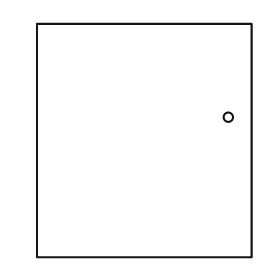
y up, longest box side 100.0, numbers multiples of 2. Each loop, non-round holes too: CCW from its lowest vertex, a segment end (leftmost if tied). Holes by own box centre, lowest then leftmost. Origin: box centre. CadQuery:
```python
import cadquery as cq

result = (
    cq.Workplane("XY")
    .moveTo(-46.0, -50.0)
    .lineTo(46.0, -50.0)
    .lineTo(46.0, 50.0)
    .lineTo(-46.0, 50.0)
    .close()
    .moveTo(36.0, 10.0)
    .circle(2.0)
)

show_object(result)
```